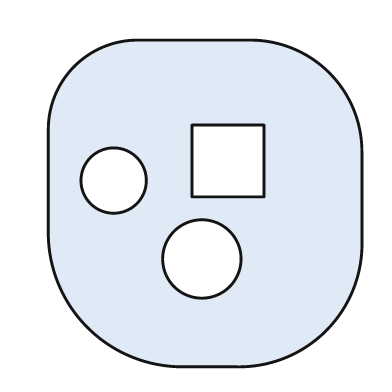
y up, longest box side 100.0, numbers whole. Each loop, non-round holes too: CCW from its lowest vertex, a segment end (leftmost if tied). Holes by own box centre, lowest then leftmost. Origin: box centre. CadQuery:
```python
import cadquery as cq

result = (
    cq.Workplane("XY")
    .moveTo(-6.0, -50.0)
    .lineTo(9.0, -50.0)
    .threePointArc((37.0, -39.0), (48.0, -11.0))
    .lineTo(48.0, 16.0)
    .threePointArc((38.0, 40.0), (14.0, 50.0))
    .lineTo(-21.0, 50.0)
    .threePointArc((-40.0, 42.0), (-48.0, 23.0))
    .lineTo(-48.0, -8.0)
    .threePointArc((-36.0, -38.0), (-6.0, -50.0))
    .close()
    .moveTo(-1.0, -17.0)
    .circle(12.0)
    .moveTo(-28.0, 7.0)
    .circle(10.0)
    .moveTo(-4.0, 2.0)
    .lineTo(18.0, 2.0)
    .lineTo(18.0, 24.0)
    .lineTo(-4.0, 24.0)
    .close()
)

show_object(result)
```